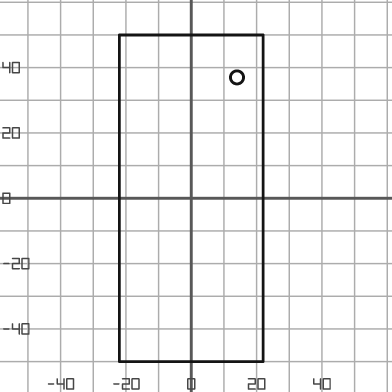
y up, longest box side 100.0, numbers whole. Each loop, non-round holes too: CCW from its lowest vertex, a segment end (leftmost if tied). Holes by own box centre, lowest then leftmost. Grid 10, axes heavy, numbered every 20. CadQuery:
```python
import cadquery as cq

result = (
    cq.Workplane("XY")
    .moveTo(-22.0, -50.0)
    .lineTo(22.0, -50.0)
    .lineTo(22.0, 50.0)
    .lineTo(-22.0, 50.0)
    .close()
    .moveTo(14.0, 37.0)
    .circle(2.0)
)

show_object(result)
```